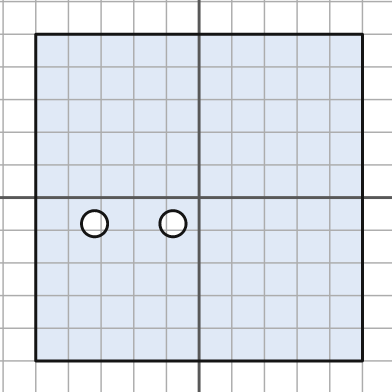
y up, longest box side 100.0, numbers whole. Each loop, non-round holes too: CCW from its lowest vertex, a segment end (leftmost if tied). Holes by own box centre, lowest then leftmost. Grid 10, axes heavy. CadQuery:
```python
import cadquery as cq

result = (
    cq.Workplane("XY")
    .moveTo(-50.0, -50.0)
    .lineTo(50.0, -50.0)
    .lineTo(50.0, 50.0)
    .lineTo(-50.0, 50.0)
    .close()
    .moveTo(-32.0, -8.0)
    .circle(4.0)
    .moveTo(-8.0, -8.0)
    .circle(4.0)
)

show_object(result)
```